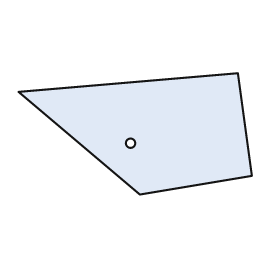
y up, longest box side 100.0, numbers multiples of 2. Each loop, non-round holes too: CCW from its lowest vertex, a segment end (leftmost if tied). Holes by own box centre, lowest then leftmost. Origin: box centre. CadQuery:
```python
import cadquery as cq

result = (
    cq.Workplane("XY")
    .moveTo(2.0, -26.0)
    .lineTo(50.0, -18.0)
    .lineTo(44.0, 26.0)
    .lineTo(-50.0, 18.0)
    .close()
    .moveTo(-2.0, -4.0)
    .circle(2.0)
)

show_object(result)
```